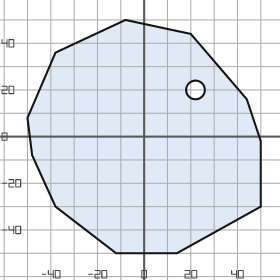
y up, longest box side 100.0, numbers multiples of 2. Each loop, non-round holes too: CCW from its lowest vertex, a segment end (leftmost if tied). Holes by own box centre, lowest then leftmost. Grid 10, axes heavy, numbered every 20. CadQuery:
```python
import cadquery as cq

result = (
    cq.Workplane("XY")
    .moveTo(-12.0, -50.0)
    .lineTo(14.0, -50.0)
    .lineTo(50.0, -30.0)
    .lineTo(50.0, -2.0)
    .lineTo(44.0, 16.0)
    .lineTo(20.0, 44.0)
    .lineTo(-8.0, 50.0)
    .lineTo(-38.0, 36.0)
    .lineTo(-50.0, 8.0)
    .lineTo(-48.0, -8.0)
    .lineTo(-38.0, -30.0)
    .close()
    .moveTo(22.0, 20.0)
    .circle(4.0)
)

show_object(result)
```